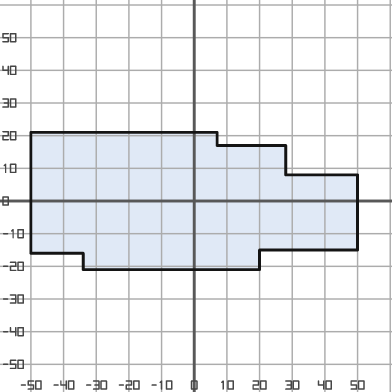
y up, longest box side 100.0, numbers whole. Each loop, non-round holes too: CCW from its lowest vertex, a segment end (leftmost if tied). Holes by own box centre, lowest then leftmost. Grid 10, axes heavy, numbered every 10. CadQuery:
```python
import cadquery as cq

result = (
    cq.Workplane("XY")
    .moveTo(-34.0, -21.0)
    .lineTo(20.0, -21.0)
    .lineTo(20.0, -15.0)
    .lineTo(50.0, -15.0)
    .lineTo(50.0, 8.0)
    .lineTo(28.0, 8.0)
    .lineTo(28.0, 17.0)
    .lineTo(7.0, 17.0)
    .lineTo(7.0, 21.0)
    .lineTo(-50.0, 21.0)
    .lineTo(-50.0, -16.0)
    .lineTo(-34.0, -16.0)
    .close()
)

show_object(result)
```